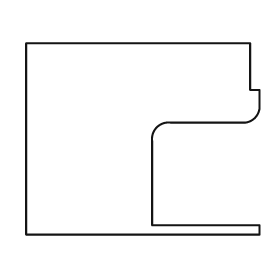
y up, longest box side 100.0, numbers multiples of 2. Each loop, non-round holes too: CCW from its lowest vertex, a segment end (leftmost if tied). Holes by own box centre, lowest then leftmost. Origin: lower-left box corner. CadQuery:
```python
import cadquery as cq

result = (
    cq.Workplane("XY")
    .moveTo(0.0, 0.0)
    .lineTo(100.0, 0.0)
    .lineTo(100.0, 4.0)
    .lineTo(54.0, 4.0)
    .lineTo(54.0, 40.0)
    .threePointArc((56.0, 46.0), (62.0, 48.0))
    .lineTo(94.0, 48.0)
    .threePointArc((98.0, 50.0), (100.0, 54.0))
    .lineTo(100.0, 62.0)
    .lineTo(96.0, 62.0)
    .lineTo(96.0, 82.0)
    .lineTo(0.0, 82.0)
    .close()
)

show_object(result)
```